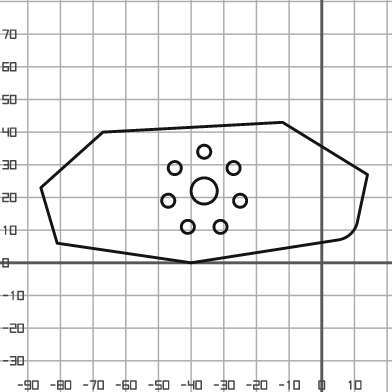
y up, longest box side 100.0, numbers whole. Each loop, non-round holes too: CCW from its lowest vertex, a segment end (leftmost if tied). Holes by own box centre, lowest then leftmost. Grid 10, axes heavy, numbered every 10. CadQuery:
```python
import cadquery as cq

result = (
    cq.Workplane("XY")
    .moveTo(-40.0, 0.0)
    .lineTo(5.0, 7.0)
    .threePointArc((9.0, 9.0), (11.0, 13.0))
    .lineTo(14.0, 27.0)
    .lineTo(-12.0, 43.0)
    .lineTo(-67.0, 40.0)
    .lineTo(-86.0, 23.0)
    .lineTo(-81.0, 6.0)
    .close()
    .moveTo(-41.0, 11.0)
    .circle(2.0)
    .moveTo(-31.0, 11.0)
    .circle(2.0)
    .moveTo(-47.0, 19.0)
    .circle(2.0)
    .moveTo(-25.0, 19.0)
    .circle(2.0)
    .moveTo(-36.0, 22.0)
    .circle(4.0)
    .moveTo(-45.0, 29.0)
    .circle(2.0)
    .moveTo(-27.0, 29.0)
    .circle(2.0)
    .moveTo(-36.0, 34.0)
    .circle(2.0)
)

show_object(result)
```